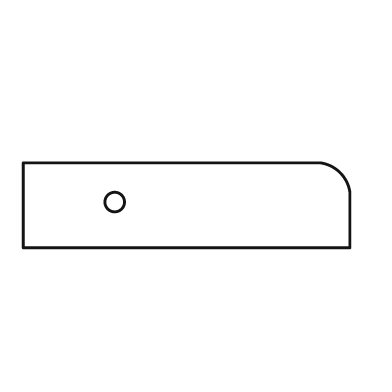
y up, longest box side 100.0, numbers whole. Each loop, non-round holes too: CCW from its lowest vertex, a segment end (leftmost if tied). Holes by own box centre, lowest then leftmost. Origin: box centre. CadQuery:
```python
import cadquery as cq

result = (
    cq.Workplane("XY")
    .moveTo(-50.0, -13.0)
    .lineTo(50.0, -13.0)
    .lineTo(50.0, 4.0)
    .threePointArc((47.0, 10.0), (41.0, 13.0))
    .lineTo(-50.0, 13.0)
    .close()
    .moveTo(-22.0, 1.0)
    .circle(3.0)
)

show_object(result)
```